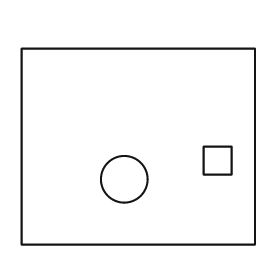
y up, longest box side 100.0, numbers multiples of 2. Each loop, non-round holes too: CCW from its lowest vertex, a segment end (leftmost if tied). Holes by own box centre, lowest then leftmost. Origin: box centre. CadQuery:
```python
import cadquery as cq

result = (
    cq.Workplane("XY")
    .moveTo(-50.0, -42.0)
    .lineTo(50.0, -42.0)
    .lineTo(50.0, 42.0)
    .lineTo(-50.0, 42.0)
    .close()
    .moveTo(-6.0, -14.0)
    .circle(10.0)
    .moveTo(28.0, -12.0)
    .lineTo(40.0, -12.0)
    .lineTo(40.0, 0.0)
    .lineTo(28.0, 0.0)
    .close()
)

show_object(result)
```